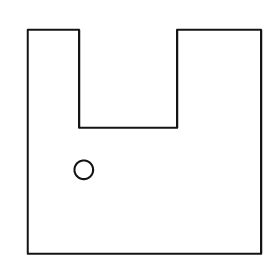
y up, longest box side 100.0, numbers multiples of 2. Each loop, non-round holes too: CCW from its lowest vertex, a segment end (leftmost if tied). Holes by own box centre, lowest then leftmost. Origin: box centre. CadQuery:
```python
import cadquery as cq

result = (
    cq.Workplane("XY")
    .moveTo(-50.0, -48.0)
    .lineTo(50.0, -48.0)
    .lineTo(50.0, 48.0)
    .lineTo(14.0, 48.0)
    .lineTo(14.0, 6.0)
    .lineTo(-28.0, 6.0)
    .lineTo(-28.0, 48.0)
    .lineTo(-50.0, 48.0)
    .close()
    .moveTo(-26.0, -12.0)
    .circle(4.0)
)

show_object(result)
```